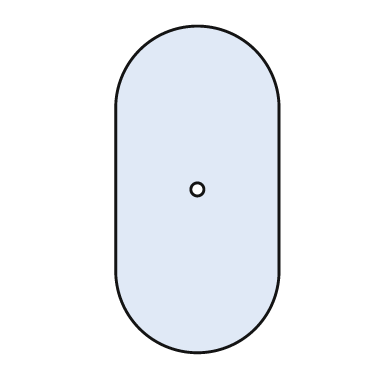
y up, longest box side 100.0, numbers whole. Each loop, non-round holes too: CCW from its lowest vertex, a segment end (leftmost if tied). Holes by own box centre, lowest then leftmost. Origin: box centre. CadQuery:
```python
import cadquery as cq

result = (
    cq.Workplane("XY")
    .moveTo(-25.0, -25.0)
    .threePointArc((0.0, -50.0), (25.0, -25.0))
    .lineTo(25.0, 25.0)
    .threePointArc((0.0, 50.0), (-25.0, 25.0))
    .close()
    .moveTo(0.0, 0.0)
    .circle(2.0)
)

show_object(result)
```